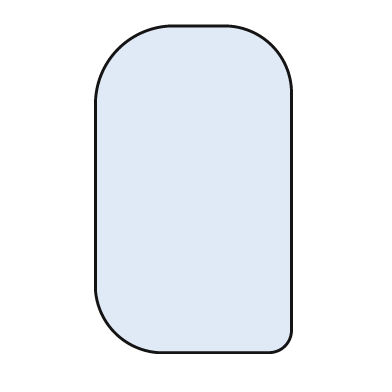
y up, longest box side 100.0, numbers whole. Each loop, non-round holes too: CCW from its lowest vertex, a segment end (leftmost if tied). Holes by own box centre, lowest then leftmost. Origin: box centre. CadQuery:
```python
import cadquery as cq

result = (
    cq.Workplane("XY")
    .moveTo(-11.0, -50.0)
    .lineTo(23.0, -50.0)
    .threePointArc((28.0, -48.0), (30.0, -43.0))
    .lineTo(30.0, 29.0)
    .threePointArc((24.0, 44.0), (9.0, 50.0))
    .lineTo(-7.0, 50.0)
    .threePointArc((-23.0, 43.0), (-30.0, 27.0))
    .lineTo(-30.0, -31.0)
    .threePointArc((-24.0, -44.0), (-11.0, -50.0))
    .close()
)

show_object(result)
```